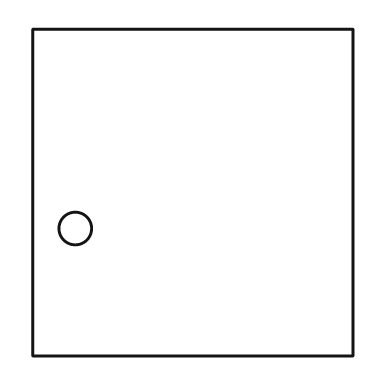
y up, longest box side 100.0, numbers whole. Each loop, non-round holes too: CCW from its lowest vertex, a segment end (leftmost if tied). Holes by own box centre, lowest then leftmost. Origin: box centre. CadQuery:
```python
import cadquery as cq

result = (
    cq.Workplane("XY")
    .moveTo(-49.0, -50.0)
    .lineTo(49.0, -50.0)
    .lineTo(49.0, 50.0)
    .lineTo(-49.0, 50.0)
    .close()
    .moveTo(-36.0, -11.0)
    .circle(5.0)
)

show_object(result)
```